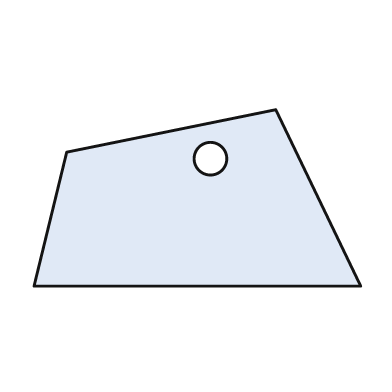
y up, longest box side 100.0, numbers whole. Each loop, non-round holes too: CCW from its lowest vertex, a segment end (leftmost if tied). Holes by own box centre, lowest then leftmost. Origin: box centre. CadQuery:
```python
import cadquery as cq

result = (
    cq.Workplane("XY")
    .moveTo(-50.0, -27.0)
    .lineTo(50.0, -27.0)
    .lineTo(24.0, 27.0)
    .lineTo(-40.0, 14.0)
    .close()
    .moveTo(4.0, 12.0)
    .circle(5.0)
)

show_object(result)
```